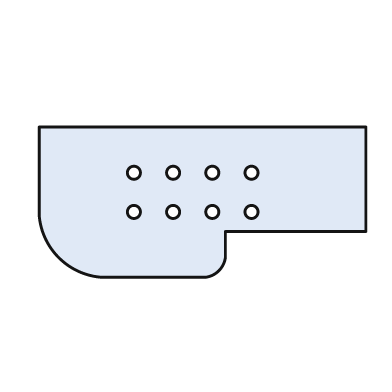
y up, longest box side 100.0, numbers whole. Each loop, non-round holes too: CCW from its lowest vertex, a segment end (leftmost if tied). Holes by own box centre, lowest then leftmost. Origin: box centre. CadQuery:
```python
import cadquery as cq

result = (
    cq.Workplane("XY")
    .moveTo(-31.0, -23.0)
    .lineTo(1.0, -23.0)
    .threePointArc((5.0, -21.0), (7.0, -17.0))
    .lineTo(7.0, -9.0)
    .lineTo(50.0, -9.0)
    .lineTo(50.0, 23.0)
    .lineTo(-50.0, 23.0)
    .lineTo(-50.0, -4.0)
    .threePointArc((-44.0, -17.0), (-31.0, -23.0))
    .close()
    .moveTo(-21.0, -3.0)
    .circle(2.0)
    .moveTo(-9.0, -3.0)
    .circle(2.0)
    .moveTo(3.0, -3.0)
    .circle(2.0)
    .moveTo(15.0, -3.0)
    .circle(2.0)
    .moveTo(-21.0, 9.0)
    .circle(2.0)
    .moveTo(-9.0, 9.0)
    .circle(2.0)
    .moveTo(3.0, 9.0)
    .circle(2.0)
    .moveTo(15.0, 9.0)
    .circle(2.0)
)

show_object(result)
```